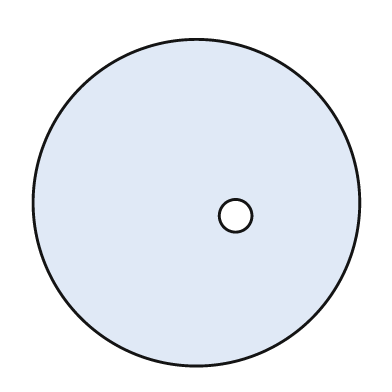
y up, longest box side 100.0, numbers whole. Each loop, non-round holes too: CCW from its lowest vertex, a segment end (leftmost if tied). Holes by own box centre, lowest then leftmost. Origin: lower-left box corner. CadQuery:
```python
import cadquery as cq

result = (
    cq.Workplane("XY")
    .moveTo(50.0, 50.0)
    .circle(50.0)
    .moveTo(62.0, 46.0)
    .circle(5.0)
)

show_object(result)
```